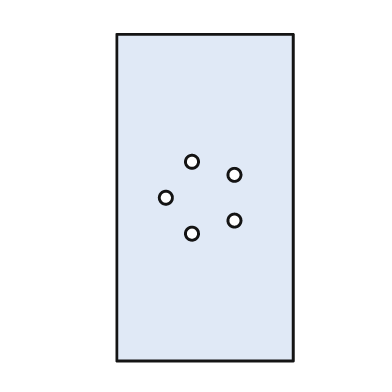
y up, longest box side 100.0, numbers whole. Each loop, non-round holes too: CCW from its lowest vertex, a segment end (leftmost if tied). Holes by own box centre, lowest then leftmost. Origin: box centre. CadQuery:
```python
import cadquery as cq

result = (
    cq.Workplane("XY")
    .moveTo(-27.0, -50.0)
    .lineTo(27.0, -50.0)
    .lineTo(27.0, 50.0)
    .lineTo(-27.0, 50.0)
    .close()
    .moveTo(-4.0, -11.0)
    .circle(2.0)
    .moveTo(9.0, -7.0)
    .circle(2.0)
    .moveTo(-12.0, 0.0)
    .circle(2.0)
    .moveTo(9.0, 7.0)
    .circle(2.0)
    .moveTo(-4.0, 11.0)
    .circle(2.0)
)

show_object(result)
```